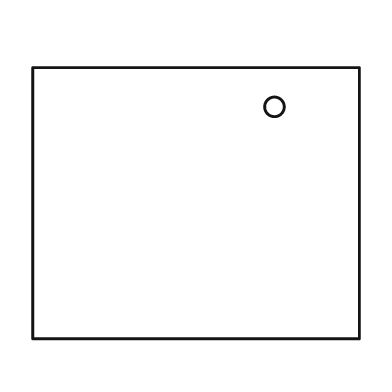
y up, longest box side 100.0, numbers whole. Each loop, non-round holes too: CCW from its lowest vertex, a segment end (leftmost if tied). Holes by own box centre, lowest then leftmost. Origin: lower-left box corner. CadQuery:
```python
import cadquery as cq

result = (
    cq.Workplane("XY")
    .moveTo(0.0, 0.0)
    .lineTo(100.0, 0.0)
    .lineTo(100.0, 83.0)
    .lineTo(0.0, 83.0)
    .close()
    .moveTo(74.0, 71.0)
    .circle(3.0)
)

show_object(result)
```